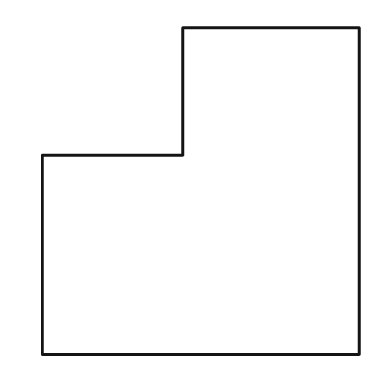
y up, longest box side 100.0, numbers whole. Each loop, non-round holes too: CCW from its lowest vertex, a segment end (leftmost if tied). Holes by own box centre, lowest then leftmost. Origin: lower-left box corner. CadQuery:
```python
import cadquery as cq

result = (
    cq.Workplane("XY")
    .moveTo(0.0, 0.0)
    .lineTo(97.0, 0.0)
    .lineTo(97.0, 100.0)
    .lineTo(43.0, 100.0)
    .lineTo(43.0, 61.0)
    .lineTo(0.0, 61.0)
    .close()
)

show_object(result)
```